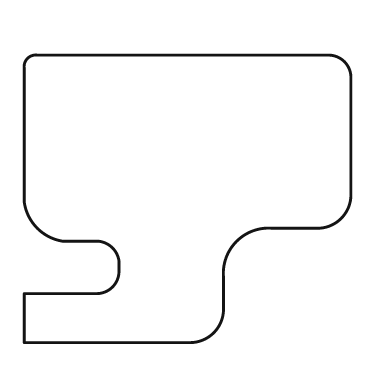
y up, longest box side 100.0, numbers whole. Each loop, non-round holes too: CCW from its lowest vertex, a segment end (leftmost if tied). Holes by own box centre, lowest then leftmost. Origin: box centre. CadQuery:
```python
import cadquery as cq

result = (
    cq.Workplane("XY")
    .moveTo(-50.0, -44.0)
    .lineTo(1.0, -44.0)
    .threePointArc((8.0, -41.0), (11.0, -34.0))
    .lineTo(11.0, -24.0)
    .threePointArc((15.0, -13.0), (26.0, -9.0))
    .lineTo(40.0, -9.0)
    .threePointArc((47.0, -6.0), (50.0, 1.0))
    .lineTo(50.0, 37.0)
    .threePointArc((48.0, 42.0), (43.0, 44.0))
    .lineTo(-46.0, 44.0)
    .threePointArc((-49.0, 43.0), (-50.0, 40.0))
    .lineTo(-50.0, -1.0)
    .threePointArc((-46.0, -9.0), (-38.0, -13.0))
    .lineTo(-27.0, -13.0)
    .threePointArc((-23.0, -15.0), (-21.0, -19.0))
    .lineTo(-21.0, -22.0)
    .threePointArc((-23.0, -27.0), (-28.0, -29.0))
    .lineTo(-50.0, -29.0)
    .close()
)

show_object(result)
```